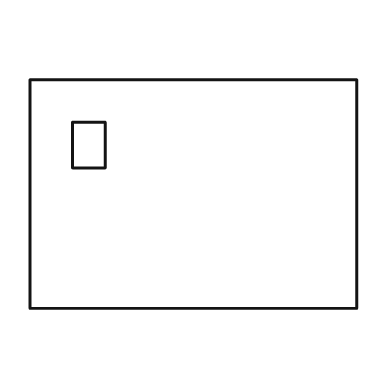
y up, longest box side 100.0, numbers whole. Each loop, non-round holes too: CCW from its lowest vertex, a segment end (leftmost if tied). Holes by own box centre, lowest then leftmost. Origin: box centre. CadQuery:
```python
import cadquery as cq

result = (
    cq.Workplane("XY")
    .moveTo(-50.0, -35.0)
    .lineTo(50.0, -35.0)
    .lineTo(50.0, 35.0)
    .lineTo(-50.0, 35.0)
    .close()
    .moveTo(-37.0, 8.0)
    .lineTo(-27.0, 8.0)
    .lineTo(-27.0, 22.0)
    .lineTo(-37.0, 22.0)
    .close()
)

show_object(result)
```